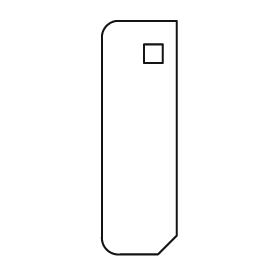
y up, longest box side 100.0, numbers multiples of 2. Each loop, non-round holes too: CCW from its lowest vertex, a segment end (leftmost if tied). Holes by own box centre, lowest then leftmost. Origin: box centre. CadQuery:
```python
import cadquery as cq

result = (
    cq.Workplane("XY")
    .moveTo(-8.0, -50.0)
    .lineTo(8.0, -50.0)
    .lineTo(16.0, -42.0)
    .lineTo(16.0, 50.0)
    .lineTo(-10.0, 50.0)
    .threePointArc((-14.0, 48.0), (-16.0, 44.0))
    .lineTo(-16.0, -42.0)
    .threePointArc((-14.0, -48.0), (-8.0, -50.0))
    .close()
    .moveTo(2.0, 32.0)
    .lineTo(10.0, 32.0)
    .lineTo(10.0, 40.0)
    .lineTo(2.0, 40.0)
    .close()
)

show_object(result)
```